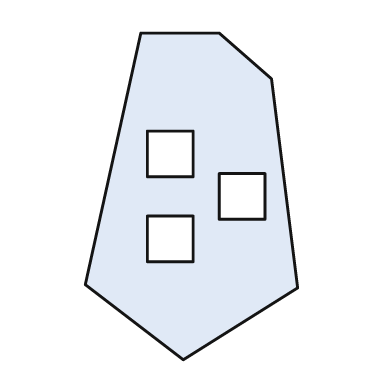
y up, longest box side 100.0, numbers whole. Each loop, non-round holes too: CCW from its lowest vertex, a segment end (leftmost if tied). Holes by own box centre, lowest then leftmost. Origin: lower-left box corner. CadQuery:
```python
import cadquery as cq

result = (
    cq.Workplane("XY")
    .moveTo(30.0, 0.0)
    .lineTo(65.0, 22.0)
    .lineTo(57.0, 86.0)
    .lineTo(41.0, 100.0)
    .lineTo(17.0, 100.0)
    .lineTo(0.0, 23.0)
    .close()
    .moveTo(19.0, 30.0)
    .lineTo(33.0, 30.0)
    .lineTo(33.0, 44.0)
    .lineTo(19.0, 44.0)
    .close()
    .moveTo(41.0, 43.0)
    .lineTo(55.0, 43.0)
    .lineTo(55.0, 57.0)
    .lineTo(41.0, 57.0)
    .close()
    .moveTo(19.0, 56.0)
    .lineTo(33.0, 56.0)
    .lineTo(33.0, 70.0)
    .lineTo(19.0, 70.0)
    .close()
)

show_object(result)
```